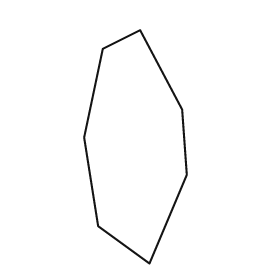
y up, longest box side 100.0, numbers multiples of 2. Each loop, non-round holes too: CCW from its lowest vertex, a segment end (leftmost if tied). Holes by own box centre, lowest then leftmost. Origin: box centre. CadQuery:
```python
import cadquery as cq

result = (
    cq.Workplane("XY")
    .moveTo(6.0, -50.0)
    .lineTo(22.0, -12.0)
    .lineTo(20.0, 16.0)
    .lineTo(2.0, 50.0)
    .lineTo(-14.0, 42.0)
    .lineTo(-22.0, 4.0)
    .lineTo(-16.0, -34.0)
    .close()
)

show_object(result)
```